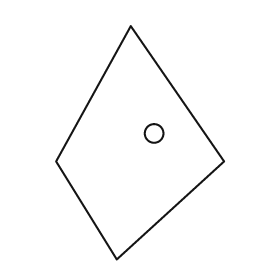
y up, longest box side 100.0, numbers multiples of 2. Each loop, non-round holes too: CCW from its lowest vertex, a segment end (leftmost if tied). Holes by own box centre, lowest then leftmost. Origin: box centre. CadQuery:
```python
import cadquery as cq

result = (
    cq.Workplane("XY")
    .moveTo(-10.0, -50.0)
    .lineTo(36.0, -8.0)
    .lineTo(-4.0, 50.0)
    .lineTo(-36.0, -8.0)
    .close()
    .moveTo(6.0, 4.0)
    .circle(4.0)
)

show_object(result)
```